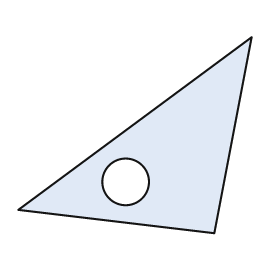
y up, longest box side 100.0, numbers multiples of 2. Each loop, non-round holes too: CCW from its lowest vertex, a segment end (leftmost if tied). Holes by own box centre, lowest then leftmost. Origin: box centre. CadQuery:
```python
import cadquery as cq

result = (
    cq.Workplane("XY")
    .moveTo(34.0, -42.0)
    .lineTo(50.0, 42.0)
    .lineTo(-50.0, -32.0)
    .close()
    .moveTo(-4.0, -20.0)
    .circle(10.0)
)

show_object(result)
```